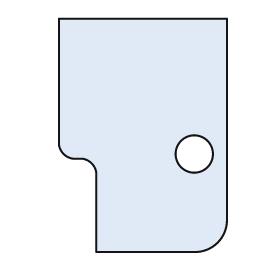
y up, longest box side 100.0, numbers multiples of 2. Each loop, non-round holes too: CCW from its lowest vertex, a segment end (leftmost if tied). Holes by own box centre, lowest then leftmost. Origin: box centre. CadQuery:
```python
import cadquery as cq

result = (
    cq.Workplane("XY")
    .moveTo(-20.0, -50.0)
    .lineTo(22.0, -50.0)
    .threePointArc((32.0, -46.0), (36.0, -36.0))
    .lineTo(36.0, 50.0)
    .lineTo(-36.0, 50.0)
    .lineTo(-36.0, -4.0)
    .threePointArc((-34.0, -8.0), (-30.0, -10.0))
    .lineTo(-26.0, -10.0)
    .threePointArc((-22.0, -12.0), (-20.0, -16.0))
    .close()
    .moveTo(22.0, -8.0)
    .circle(8.0)
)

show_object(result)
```